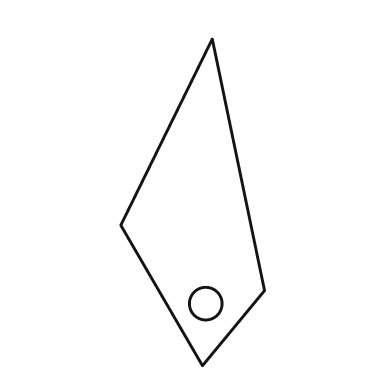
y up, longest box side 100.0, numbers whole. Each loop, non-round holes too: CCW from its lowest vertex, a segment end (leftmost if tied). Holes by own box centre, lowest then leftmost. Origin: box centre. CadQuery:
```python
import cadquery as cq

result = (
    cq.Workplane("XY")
    .moveTo(3.0, -50.0)
    .lineTo(22.0, -27.0)
    .lineTo(6.0, 50.0)
    .lineTo(-22.0, -7.0)
    .close()
    .moveTo(4.0, -31.0)
    .circle(5.0)
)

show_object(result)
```